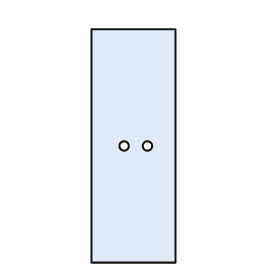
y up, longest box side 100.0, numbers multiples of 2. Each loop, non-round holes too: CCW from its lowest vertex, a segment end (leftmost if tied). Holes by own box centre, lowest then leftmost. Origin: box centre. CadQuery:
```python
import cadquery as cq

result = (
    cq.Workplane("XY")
    .moveTo(-18.0, -50.0)
    .lineTo(18.0, -50.0)
    .lineTo(18.0, 50.0)
    .lineTo(-18.0, 50.0)
    .close()
    .moveTo(-4.0, 0.0)
    .circle(2.0)
    .moveTo(6.0, 0.0)
    .circle(2.0)
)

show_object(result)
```